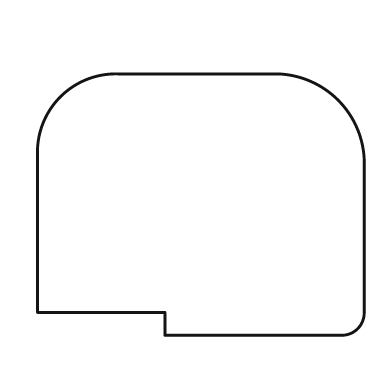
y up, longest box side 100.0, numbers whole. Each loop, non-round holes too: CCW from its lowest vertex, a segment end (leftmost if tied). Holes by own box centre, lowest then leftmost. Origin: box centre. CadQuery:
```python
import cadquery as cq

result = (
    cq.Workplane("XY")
    .moveTo(-11.0, -40.0)
    .lineTo(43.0, -40.0)
    .threePointArc((48.0, -38.0), (50.0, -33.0))
    .lineTo(50.0, 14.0)
    .threePointArc((42.0, 32.0), (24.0, 40.0))
    .lineTo(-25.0, 40.0)
    .threePointArc((-43.0, 33.0), (-50.0, 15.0))
    .lineTo(-50.0, -33.0)
    .lineTo(-11.0, -33.0)
    .close()
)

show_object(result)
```